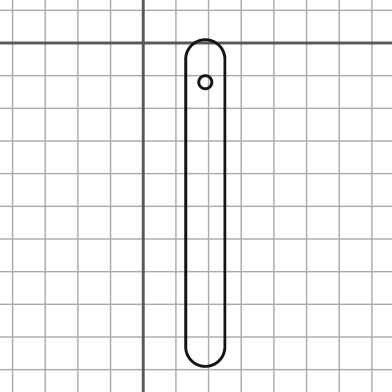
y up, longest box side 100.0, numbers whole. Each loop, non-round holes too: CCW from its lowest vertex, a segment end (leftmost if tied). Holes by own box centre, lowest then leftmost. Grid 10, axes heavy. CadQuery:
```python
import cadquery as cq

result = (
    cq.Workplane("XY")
    .moveTo(13.0, -93.0)
    .threePointArc((19.0, -99.0), (25.0, -93.0))
    .lineTo(25.0, -5.0)
    .threePointArc((19.0, 1.0), (13.0, -5.0))
    .close()
    .moveTo(19.0, -12.0)
    .circle(2.0)
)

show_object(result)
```